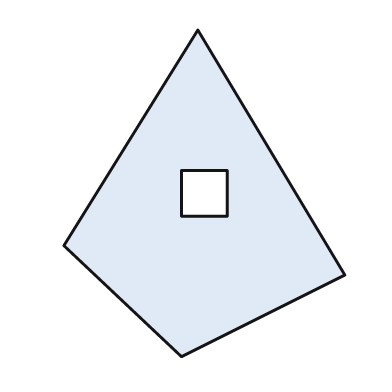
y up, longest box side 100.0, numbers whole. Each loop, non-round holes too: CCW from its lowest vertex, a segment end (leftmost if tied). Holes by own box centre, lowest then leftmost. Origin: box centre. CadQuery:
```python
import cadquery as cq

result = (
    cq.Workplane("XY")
    .moveTo(-7.0, -50.0)
    .lineTo(43.0, -25.0)
    .lineTo(-2.0, 50.0)
    .lineTo(-43.0, -16.0)
    .close()
    .moveTo(-7.0, -7.0)
    .lineTo(7.0, -7.0)
    .lineTo(7.0, 7.0)
    .lineTo(-7.0, 7.0)
    .close()
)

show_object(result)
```